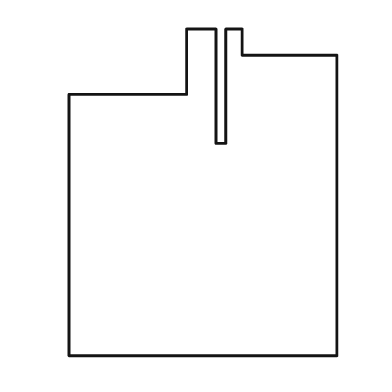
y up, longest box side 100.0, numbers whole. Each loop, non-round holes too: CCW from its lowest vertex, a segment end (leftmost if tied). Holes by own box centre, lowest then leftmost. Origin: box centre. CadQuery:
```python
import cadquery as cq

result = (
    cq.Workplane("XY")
    .moveTo(-41.0, -50.0)
    .lineTo(41.0, -50.0)
    .lineTo(41.0, 42.0)
    .lineTo(12.0, 42.0)
    .lineTo(12.0, 50.0)
    .lineTo(7.0, 50.0)
    .lineTo(7.0, 15.0)
    .lineTo(4.0, 15.0)
    .lineTo(4.0, 50.0)
    .lineTo(-5.0, 50.0)
    .lineTo(-5.0, 30.0)
    .lineTo(-41.0, 30.0)
    .close()
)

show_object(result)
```